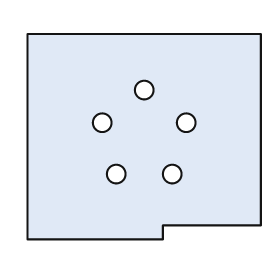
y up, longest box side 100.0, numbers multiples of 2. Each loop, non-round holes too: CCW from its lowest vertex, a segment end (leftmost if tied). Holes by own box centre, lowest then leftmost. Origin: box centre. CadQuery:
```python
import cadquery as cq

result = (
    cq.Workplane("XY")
    .moveTo(-50.0, -44.0)
    .lineTo(8.0, -44.0)
    .lineTo(8.0, -38.0)
    .lineTo(50.0, -38.0)
    .lineTo(50.0, 44.0)
    .lineTo(-50.0, 44.0)
    .close()
    .moveTo(-12.0, -16.0)
    .circle(4.0)
    .moveTo(12.0, -16.0)
    .circle(4.0)
    .moveTo(-18.0, 6.0)
    .circle(4.0)
    .moveTo(18.0, 6.0)
    .circle(4.0)
    .moveTo(0.0, 20.0)
    .circle(4.0)
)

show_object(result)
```